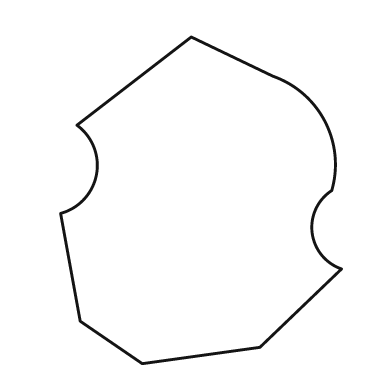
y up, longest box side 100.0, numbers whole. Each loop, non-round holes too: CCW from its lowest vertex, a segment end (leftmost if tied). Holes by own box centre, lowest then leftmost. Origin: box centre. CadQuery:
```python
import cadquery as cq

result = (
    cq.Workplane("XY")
    .moveTo(-18.0, -50.0)
    .lineTo(18.0, -45.0)
    .lineTo(43.0, -21.0)
    .threePointArc((34.0, -10.0), (40.0, 3.0))
    .threePointArc((38.0, 24.0), (22.0, 38.0))
    .lineTo(-3.0, 50.0)
    .lineTo(-38.0, 23.0)
    .threePointArc((-32.0, 8.0), (-43.0, -4.0))
    .lineTo(-37.0, -37.0)
    .close()
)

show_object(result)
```